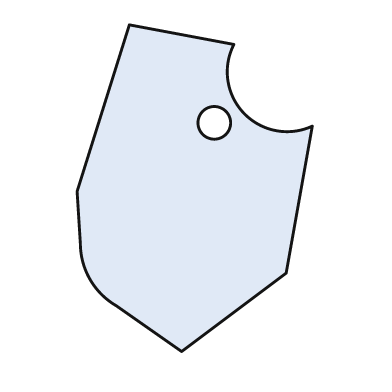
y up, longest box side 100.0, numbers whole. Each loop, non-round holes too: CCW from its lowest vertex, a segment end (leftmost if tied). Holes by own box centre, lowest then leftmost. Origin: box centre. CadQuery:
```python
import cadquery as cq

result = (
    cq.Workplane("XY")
    .moveTo(-4.0, -50.0)
    .lineTo(28.0, -26.0)
    .lineTo(36.0, 19.0)
    .threePointArc((15.0, 23.0), (12.0, 44.0))
    .lineTo(-20.0, 50.0)
    .lineTo(-36.0, -1.0)
    .lineTo(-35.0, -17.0)
    .threePointArc((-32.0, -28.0), (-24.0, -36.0))
    .close()
    .moveTo(6.0, 20.0)
    .circle(5.0)
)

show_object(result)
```